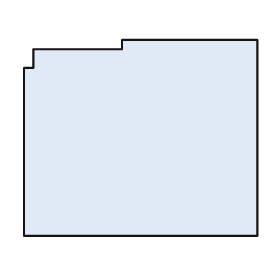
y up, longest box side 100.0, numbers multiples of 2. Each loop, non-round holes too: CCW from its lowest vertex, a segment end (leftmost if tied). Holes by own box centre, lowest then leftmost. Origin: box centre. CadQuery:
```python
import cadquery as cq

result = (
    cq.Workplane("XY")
    .moveTo(-50.0, -42.0)
    .lineTo(50.0, -42.0)
    .lineTo(50.0, 42.0)
    .lineTo(-8.0, 42.0)
    .lineTo(-8.0, 38.0)
    .lineTo(-46.0, 38.0)
    .lineTo(-46.0, 30.0)
    .lineTo(-50.0, 30.0)
    .close()
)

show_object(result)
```